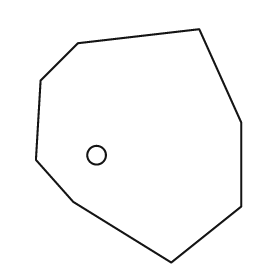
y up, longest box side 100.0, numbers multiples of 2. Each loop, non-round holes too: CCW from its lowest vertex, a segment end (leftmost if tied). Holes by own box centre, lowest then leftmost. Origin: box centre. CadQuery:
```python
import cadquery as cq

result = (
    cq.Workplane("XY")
    .moveTo(14.0, -50.0)
    .lineTo(44.0, -26.0)
    .lineTo(44.0, 10.0)
    .lineTo(26.0, 50.0)
    .lineTo(-26.0, 44.0)
    .lineTo(-42.0, 28.0)
    .lineTo(-44.0, -6.0)
    .lineTo(-28.0, -24.0)
    .close()
    .moveTo(-18.0, -4.0)
    .circle(4.0)
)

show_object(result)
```